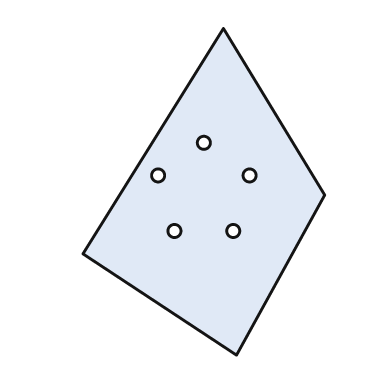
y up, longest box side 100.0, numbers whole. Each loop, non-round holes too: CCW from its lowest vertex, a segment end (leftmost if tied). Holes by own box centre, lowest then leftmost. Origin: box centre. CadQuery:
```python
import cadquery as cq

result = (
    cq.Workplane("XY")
    .moveTo(10.0, -50.0)
    .lineTo(37.0, -1.0)
    .lineTo(6.0, 50.0)
    .lineTo(-37.0, -19.0)
    .close()
    .moveTo(-9.0, -12.0)
    .circle(2.0)
    .moveTo(9.0, -12.0)
    .circle(2.0)
    .moveTo(-14.0, 5.0)
    .circle(2.0)
    .moveTo(14.0, 5.0)
    .circle(2.0)
    .moveTo(0.0, 15.0)
    .circle(2.0)
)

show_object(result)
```